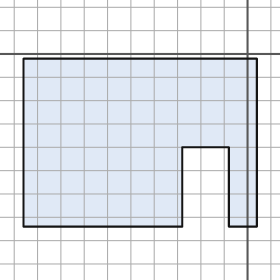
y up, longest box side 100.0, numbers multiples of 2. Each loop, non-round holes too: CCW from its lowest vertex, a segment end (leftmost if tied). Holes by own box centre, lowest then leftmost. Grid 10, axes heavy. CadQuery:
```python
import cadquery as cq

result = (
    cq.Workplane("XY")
    .moveTo(-96.0, -74.0)
    .lineTo(-28.0, -74.0)
    .lineTo(-28.0, -40.0)
    .lineTo(-8.0, -40.0)
    .lineTo(-8.0, -74.0)
    .lineTo(4.0, -74.0)
    .lineTo(4.0, -2.0)
    .lineTo(-96.0, -2.0)
    .close()
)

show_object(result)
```